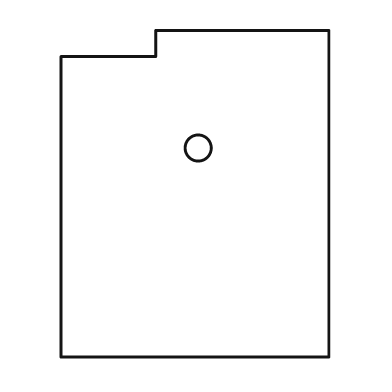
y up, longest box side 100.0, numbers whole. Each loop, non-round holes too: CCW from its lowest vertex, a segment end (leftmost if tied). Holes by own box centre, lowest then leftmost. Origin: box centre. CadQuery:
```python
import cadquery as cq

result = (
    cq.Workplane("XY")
    .moveTo(-41.0, -50.0)
    .lineTo(41.0, -50.0)
    .lineTo(41.0, 50.0)
    .lineTo(-12.0, 50.0)
    .lineTo(-12.0, 42.0)
    .lineTo(-41.0, 42.0)
    .close()
    .moveTo(1.0, 14.0)
    .circle(4.0)
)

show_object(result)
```